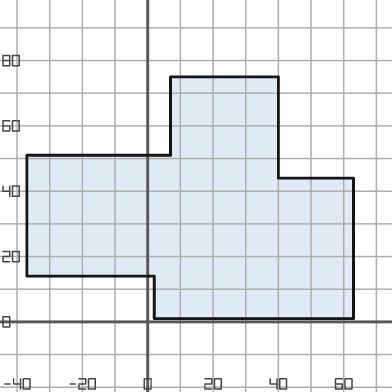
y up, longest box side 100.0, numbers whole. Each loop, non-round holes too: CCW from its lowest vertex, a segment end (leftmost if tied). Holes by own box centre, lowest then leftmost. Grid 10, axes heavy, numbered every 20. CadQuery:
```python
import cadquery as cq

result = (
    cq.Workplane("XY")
    .moveTo(2.0, 1.0)
    .lineTo(63.0, 1.0)
    .lineTo(63.0, 44.0)
    .lineTo(40.0, 44.0)
    .lineTo(40.0, 75.0)
    .lineTo(7.0, 75.0)
    .lineTo(7.0, 51.0)
    .lineTo(-37.0, 51.0)
    .lineTo(-37.0, 14.0)
    .lineTo(2.0, 14.0)
    .close()
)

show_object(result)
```